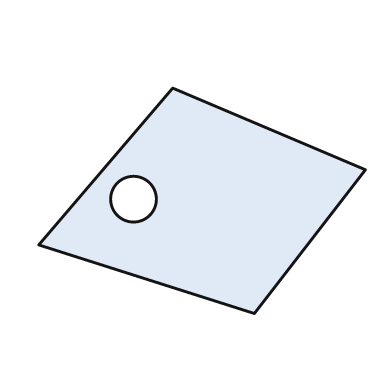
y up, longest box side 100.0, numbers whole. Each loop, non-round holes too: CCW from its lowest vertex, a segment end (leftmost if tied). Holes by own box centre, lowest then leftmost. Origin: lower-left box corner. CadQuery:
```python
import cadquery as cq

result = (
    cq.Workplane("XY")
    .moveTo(66.0, 0.0)
    .lineTo(100.0, 44.0)
    .lineTo(41.0, 69.0)
    .lineTo(0.0, 21.0)
    .close()
    .moveTo(29.0, 35.0)
    .circle(7.0)
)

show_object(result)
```